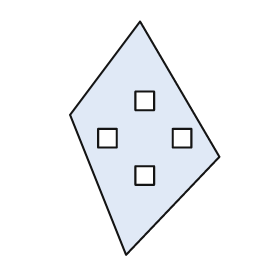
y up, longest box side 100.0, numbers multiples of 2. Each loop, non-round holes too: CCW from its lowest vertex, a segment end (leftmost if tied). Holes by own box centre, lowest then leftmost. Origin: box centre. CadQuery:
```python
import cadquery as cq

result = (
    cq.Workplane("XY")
    .moveTo(-8.0, -50.0)
    .lineTo(32.0, -8.0)
    .lineTo(-2.0, 50.0)
    .lineTo(-32.0, 10.0)
    .close()
    .moveTo(-4.0, -20.0)
    .lineTo(4.0, -20.0)
    .lineTo(4.0, -12.0)
    .lineTo(-4.0, -12.0)
    .close()
    .moveTo(-20.0, -4.0)
    .lineTo(-12.0, -4.0)
    .lineTo(-12.0, 4.0)
    .lineTo(-20.0, 4.0)
    .close()
    .moveTo(12.0, -4.0)
    .lineTo(20.0, -4.0)
    .lineTo(20.0, 4.0)
    .lineTo(12.0, 4.0)
    .close()
    .moveTo(-4.0, 12.0)
    .lineTo(4.0, 12.0)
    .lineTo(4.0, 20.0)
    .lineTo(-4.0, 20.0)
    .close()
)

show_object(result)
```